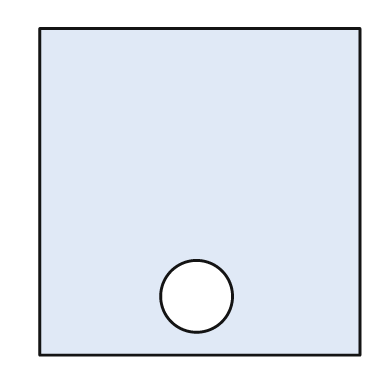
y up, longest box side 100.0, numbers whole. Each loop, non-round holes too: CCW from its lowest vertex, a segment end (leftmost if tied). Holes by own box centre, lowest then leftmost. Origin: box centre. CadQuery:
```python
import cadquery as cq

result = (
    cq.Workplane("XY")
    .moveTo(-49.0, -50.0)
    .lineTo(49.0, -50.0)
    .lineTo(49.0, 50.0)
    .lineTo(-49.0, 50.0)
    .close()
    .moveTo(-1.0, -32.0)
    .circle(11.0)
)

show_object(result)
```